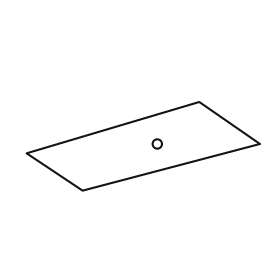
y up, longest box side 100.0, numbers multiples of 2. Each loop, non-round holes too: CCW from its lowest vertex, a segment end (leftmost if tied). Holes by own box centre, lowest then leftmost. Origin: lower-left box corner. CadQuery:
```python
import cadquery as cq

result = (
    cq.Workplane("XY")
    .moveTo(24.0, 0.0)
    .lineTo(100.0, 20.0)
    .lineTo(74.0, 38.0)
    .lineTo(0.0, 16.0)
    .close()
    .moveTo(56.0, 20.0)
    .circle(2.0)
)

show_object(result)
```